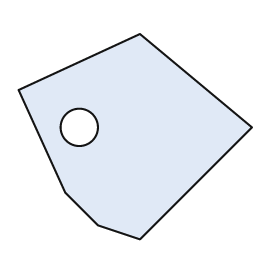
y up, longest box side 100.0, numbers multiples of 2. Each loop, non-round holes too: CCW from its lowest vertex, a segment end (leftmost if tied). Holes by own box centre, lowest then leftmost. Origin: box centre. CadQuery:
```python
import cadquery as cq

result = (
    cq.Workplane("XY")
    .moveTo(2.0, -44.0)
    .lineTo(50.0, 4.0)
    .lineTo(2.0, 44.0)
    .lineTo(-50.0, 20.0)
    .lineTo(-30.0, -24.0)
    .lineTo(-16.0, -38.0)
    .close()
    .moveTo(-24.0, 4.0)
    .circle(8.0)
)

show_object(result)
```